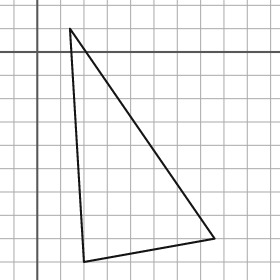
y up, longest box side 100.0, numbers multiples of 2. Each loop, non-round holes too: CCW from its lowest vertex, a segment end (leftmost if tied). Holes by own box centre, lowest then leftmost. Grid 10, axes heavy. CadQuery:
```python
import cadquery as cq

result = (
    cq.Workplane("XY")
    .moveTo(20.0, -90.0)
    .lineTo(76.0, -80.0)
    .lineTo(14.0, 10.0)
    .close()
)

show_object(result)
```